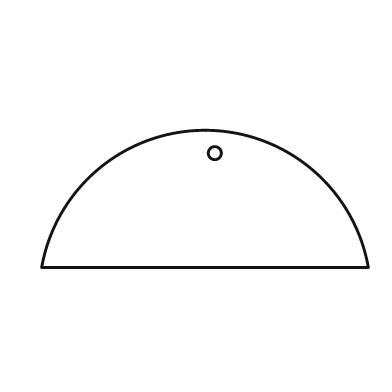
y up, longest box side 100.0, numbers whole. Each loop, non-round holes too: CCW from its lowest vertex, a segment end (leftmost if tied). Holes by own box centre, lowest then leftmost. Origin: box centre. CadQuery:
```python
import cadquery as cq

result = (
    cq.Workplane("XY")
    .moveTo(-50.0, -21.0)
    .lineTo(50.0, -21.0)
    .threePointArc((0.0, 21.0), (-50.0, -21.0))
    .close()
    .moveTo(3.0, 14.0)
    .circle(2.0)
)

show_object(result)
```